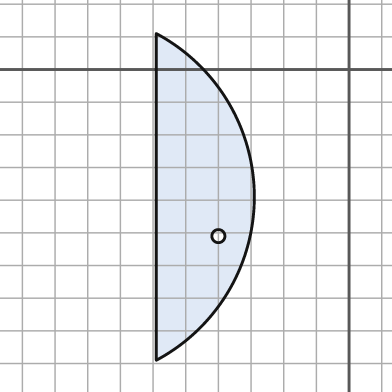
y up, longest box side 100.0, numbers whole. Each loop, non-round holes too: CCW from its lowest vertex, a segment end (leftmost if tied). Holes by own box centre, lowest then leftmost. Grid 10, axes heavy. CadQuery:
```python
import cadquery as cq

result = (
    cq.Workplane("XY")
    .moveTo(-59.0, -89.0)
    .threePointArc((-29.0, -39.0), (-59.0, 11.0))
    .close()
    .moveTo(-40.0, -51.0)
    .circle(2.0)
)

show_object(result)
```